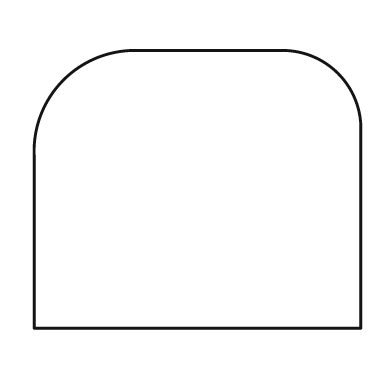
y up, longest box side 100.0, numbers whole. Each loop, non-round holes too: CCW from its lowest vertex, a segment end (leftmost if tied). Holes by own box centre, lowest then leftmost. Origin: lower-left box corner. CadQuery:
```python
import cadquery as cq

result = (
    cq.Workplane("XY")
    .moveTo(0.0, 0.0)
    .lineTo(100.0, 0.0)
    .lineTo(100.0, 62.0)
    .threePointArc((93.0, 78.0), (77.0, 85.0))
    .lineTo(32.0, 85.0)
    .threePointArc((9.0, 76.0), (0.0, 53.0))
    .close()
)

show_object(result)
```